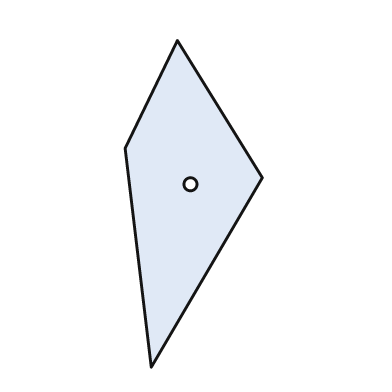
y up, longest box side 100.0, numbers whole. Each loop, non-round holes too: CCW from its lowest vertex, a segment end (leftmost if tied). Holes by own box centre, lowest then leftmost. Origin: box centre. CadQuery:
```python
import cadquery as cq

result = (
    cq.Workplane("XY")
    .moveTo(-13.0, -50.0)
    .lineTo(21.0, 8.0)
    .lineTo(-5.0, 50.0)
    .lineTo(-21.0, 17.0)
    .close()
    .moveTo(-1.0, 6.0)
    .circle(2.0)
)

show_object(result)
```